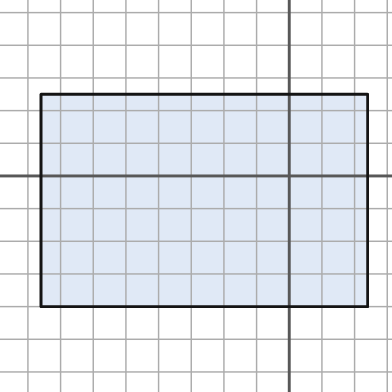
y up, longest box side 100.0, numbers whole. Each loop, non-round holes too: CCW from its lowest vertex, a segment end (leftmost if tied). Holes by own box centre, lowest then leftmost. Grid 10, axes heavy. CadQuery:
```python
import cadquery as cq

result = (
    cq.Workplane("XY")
    .moveTo(-76.0, -40.0)
    .lineTo(24.0, -40.0)
    .lineTo(24.0, 25.0)
    .lineTo(-76.0, 25.0)
    .close()
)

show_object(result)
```